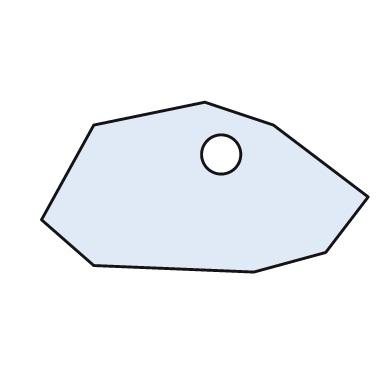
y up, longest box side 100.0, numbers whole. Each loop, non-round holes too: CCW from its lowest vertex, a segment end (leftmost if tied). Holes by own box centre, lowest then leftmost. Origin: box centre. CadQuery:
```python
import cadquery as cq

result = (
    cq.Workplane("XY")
    .moveTo(15.0, -26.0)
    .lineTo(37.0, -20.0)
    .lineTo(50.0, -3.0)
    .lineTo(21.0, 19.0)
    .lineTo(0.0, 26.0)
    .lineTo(-34.0, 19.0)
    .lineTo(-50.0, -10.0)
    .lineTo(-34.0, -24.0)
    .close()
    .moveTo(5.0, 10.0)
    .circle(6.0)
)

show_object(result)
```